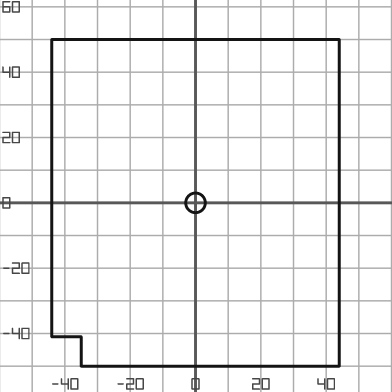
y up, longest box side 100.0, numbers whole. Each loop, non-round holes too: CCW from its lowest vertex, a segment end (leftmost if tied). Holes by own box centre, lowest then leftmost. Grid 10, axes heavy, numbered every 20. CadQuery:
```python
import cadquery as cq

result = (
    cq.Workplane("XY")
    .moveTo(-35.0, -50.0)
    .lineTo(44.0, -50.0)
    .lineTo(44.0, 50.0)
    .lineTo(-44.0, 50.0)
    .lineTo(-44.0, -41.0)
    .lineTo(-35.0, -41.0)
    .close()
    .moveTo(0.0, 0.0)
    .circle(3.0)
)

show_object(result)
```